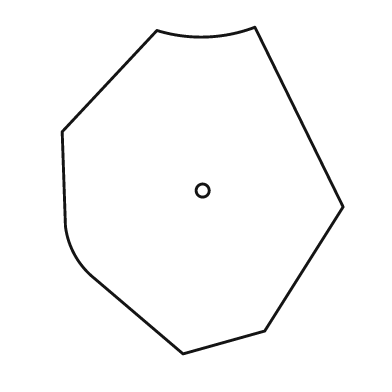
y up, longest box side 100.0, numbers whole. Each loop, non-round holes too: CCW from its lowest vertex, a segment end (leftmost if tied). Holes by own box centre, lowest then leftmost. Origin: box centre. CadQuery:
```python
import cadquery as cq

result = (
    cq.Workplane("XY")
    .moveTo(-6.0, -50.0)
    .lineTo(19.0, -43.0)
    .lineTo(43.0, -5.0)
    .lineTo(16.0, 50.0)
    .threePointArc((1.0, 47.0), (-14.0, 49.0))
    .lineTo(-43.0, 18.0)
    .lineTo(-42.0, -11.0)
    .threePointArc((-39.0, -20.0), (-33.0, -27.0))
    .close()
    .moveTo(0.0, 0.0)
    .circle(2.0)
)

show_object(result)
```